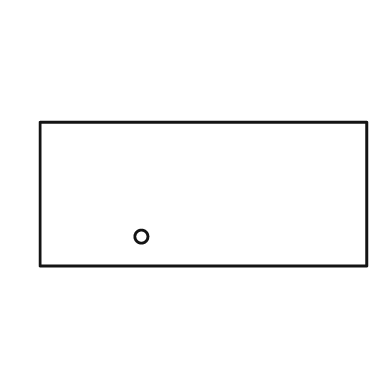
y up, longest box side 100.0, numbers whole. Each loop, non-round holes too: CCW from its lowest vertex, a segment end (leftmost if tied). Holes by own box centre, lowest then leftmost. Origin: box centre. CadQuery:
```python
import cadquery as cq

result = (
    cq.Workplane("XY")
    .moveTo(-50.0, -22.0)
    .lineTo(50.0, -22.0)
    .lineTo(50.0, 22.0)
    .lineTo(-50.0, 22.0)
    .close()
    .moveTo(-19.0, -13.0)
    .circle(2.0)
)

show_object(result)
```